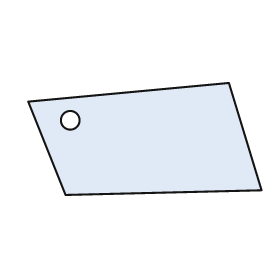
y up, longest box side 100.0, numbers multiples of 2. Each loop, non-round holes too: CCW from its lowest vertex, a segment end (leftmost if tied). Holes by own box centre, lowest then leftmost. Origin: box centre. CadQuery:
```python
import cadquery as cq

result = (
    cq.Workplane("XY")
    .moveTo(-34.0, -24.0)
    .lineTo(50.0, -22.0)
    .lineTo(36.0, 24.0)
    .lineTo(-50.0, 16.0)
    .close()
    .moveTo(-32.0, 8.0)
    .circle(4.0)
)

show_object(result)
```